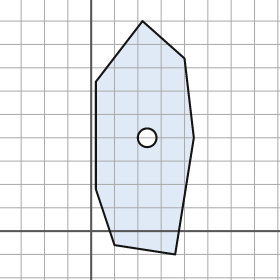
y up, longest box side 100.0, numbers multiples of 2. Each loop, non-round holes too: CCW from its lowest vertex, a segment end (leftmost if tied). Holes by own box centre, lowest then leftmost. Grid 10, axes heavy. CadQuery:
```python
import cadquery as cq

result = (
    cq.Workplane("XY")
    .moveTo(36.0, -10.0)
    .lineTo(44.0, 40.0)
    .lineTo(40.0, 74.0)
    .lineTo(22.0, 90.0)
    .lineTo(2.0, 64.0)
    .lineTo(2.0, 18.0)
    .lineTo(10.0, -6.0)
    .close()
    .moveTo(24.0, 40.0)
    .circle(4.0)
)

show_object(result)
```